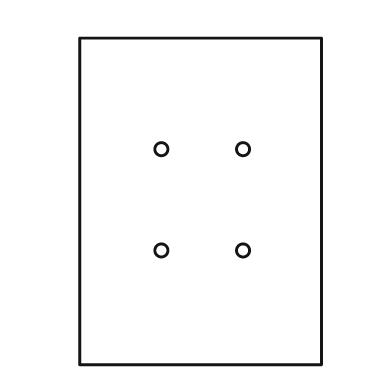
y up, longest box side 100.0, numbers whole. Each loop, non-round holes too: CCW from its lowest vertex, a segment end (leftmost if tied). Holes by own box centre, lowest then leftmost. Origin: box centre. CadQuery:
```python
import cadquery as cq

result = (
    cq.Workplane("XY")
    .moveTo(-37.0, -50.0)
    .lineTo(37.0, -50.0)
    .lineTo(37.0, 50.0)
    .lineTo(-37.0, 50.0)
    .close()
    .moveTo(-12.0, -15.0)
    .circle(2.0)
    .moveTo(13.0, -15.0)
    .circle(2.0)
    .moveTo(-12.0, 16.0)
    .circle(2.0)
    .moveTo(13.0, 16.0)
    .circle(2.0)
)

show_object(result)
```